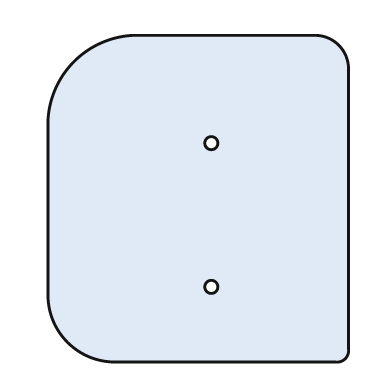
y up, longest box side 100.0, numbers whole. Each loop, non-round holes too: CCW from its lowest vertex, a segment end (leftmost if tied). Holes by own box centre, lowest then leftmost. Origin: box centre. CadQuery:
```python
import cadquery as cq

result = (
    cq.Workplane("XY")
    .moveTo(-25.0, -50.0)
    .lineTo(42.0, -50.0)
    .threePointArc((45.0, -49.0), (46.0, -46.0))
    .lineTo(46.0, 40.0)
    .threePointArc((43.0, 47.0), (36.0, 50.0))
    .lineTo(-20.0, 50.0)
    .threePointArc((-38.0, 42.0), (-46.0, 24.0))
    .lineTo(-46.0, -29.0)
    .threePointArc((-40.0, -44.0), (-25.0, -50.0))
    .close()
    .moveTo(4.0, -27.0)
    .circle(2.0)
    .moveTo(4.0, 17.0)
    .circle(2.0)
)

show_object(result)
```